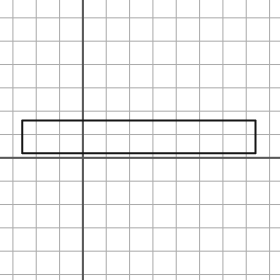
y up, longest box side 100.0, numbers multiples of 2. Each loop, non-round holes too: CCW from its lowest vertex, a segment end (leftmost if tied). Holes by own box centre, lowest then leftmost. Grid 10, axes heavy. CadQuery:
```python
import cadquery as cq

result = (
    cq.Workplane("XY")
    .moveTo(-26.0, 2.0)
    .lineTo(74.0, 2.0)
    .lineTo(74.0, 16.0)
    .lineTo(-26.0, 16.0)
    .close()
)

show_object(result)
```